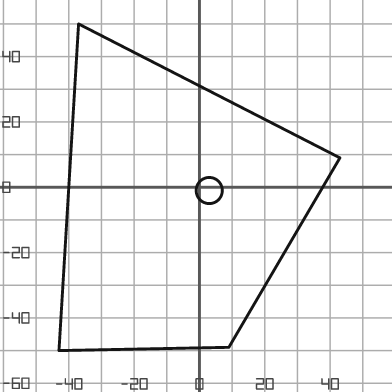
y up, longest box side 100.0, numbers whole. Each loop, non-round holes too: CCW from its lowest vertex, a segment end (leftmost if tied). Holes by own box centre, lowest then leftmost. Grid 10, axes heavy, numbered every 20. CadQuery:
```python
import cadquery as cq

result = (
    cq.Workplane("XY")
    .moveTo(-43.0, -50.0)
    .lineTo(9.0, -49.0)
    .lineTo(43.0, 9.0)
    .lineTo(-37.0, 50.0)
    .close()
    .moveTo(3.0, -1.0)
    .circle(4.0)
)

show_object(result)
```